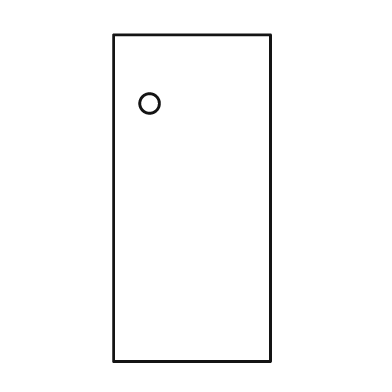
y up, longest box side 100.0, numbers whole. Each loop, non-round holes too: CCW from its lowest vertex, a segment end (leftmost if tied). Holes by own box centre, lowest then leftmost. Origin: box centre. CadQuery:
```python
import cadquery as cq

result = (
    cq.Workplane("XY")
    .moveTo(-24.0, -50.0)
    .lineTo(24.0, -50.0)
    .lineTo(24.0, 50.0)
    .lineTo(-24.0, 50.0)
    .close()
    .moveTo(-13.0, 29.0)
    .circle(3.0)
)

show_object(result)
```